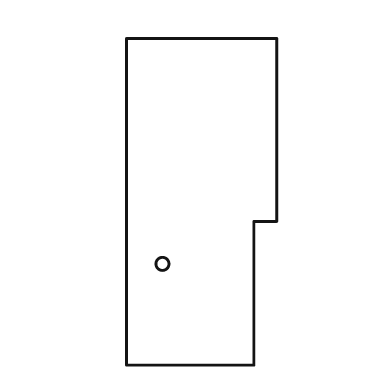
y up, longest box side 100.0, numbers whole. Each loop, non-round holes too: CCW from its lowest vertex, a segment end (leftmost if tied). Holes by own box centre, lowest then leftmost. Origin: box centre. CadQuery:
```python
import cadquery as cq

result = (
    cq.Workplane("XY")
    .moveTo(-23.0, -50.0)
    .lineTo(16.0, -50.0)
    .lineTo(16.0, -6.0)
    .lineTo(23.0, -6.0)
    .lineTo(23.0, 50.0)
    .lineTo(-23.0, 50.0)
    .close()
    .moveTo(-12.0, -19.0)
    .circle(2.0)
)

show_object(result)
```